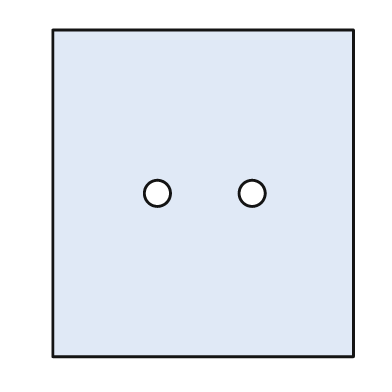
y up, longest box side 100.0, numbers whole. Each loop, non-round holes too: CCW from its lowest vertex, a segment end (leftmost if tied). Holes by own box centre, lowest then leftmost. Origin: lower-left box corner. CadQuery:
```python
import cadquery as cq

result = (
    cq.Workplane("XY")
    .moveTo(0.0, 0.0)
    .lineTo(92.0, 0.0)
    .lineTo(92.0, 100.0)
    .lineTo(0.0, 100.0)
    .close()
    .moveTo(32.0, 50.0)
    .circle(4.0)
    .moveTo(61.0, 50.0)
    .circle(4.0)
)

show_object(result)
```